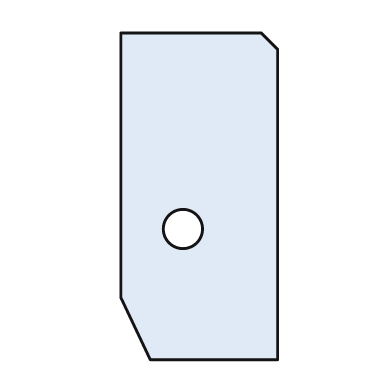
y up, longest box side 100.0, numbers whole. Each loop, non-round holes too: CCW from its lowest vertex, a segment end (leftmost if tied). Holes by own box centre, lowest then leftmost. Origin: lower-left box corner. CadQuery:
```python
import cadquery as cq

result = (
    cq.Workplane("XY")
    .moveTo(9.0, 0.0)
    .lineTo(48.0, 0.0)
    .lineTo(48.0, 95.0)
    .lineTo(43.0, 100.0)
    .lineTo(0.0, 100.0)
    .lineTo(0.0, 19.0)
    .close()
    .moveTo(19.0, 40.0)
    .circle(6.0)
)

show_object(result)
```